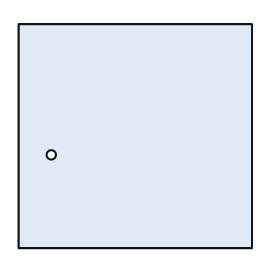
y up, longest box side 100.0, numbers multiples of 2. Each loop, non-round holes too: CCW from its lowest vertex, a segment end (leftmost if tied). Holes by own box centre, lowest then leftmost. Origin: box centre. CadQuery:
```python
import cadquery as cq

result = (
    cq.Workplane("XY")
    .moveTo(-50.0, -48.0)
    .lineTo(50.0, -48.0)
    .lineTo(50.0, 48.0)
    .lineTo(-50.0, 48.0)
    .close()
    .moveTo(-36.0, -8.0)
    .circle(2.0)
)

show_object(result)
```